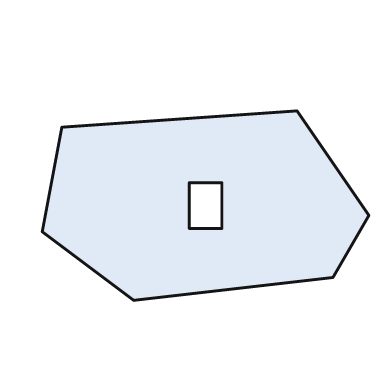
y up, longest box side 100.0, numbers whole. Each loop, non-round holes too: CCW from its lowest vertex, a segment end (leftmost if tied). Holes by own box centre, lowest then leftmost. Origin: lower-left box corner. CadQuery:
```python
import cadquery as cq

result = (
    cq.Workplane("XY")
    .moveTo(28.0, 0.0)
    .lineTo(89.0, 7.0)
    .lineTo(100.0, 26.0)
    .lineTo(78.0, 58.0)
    .lineTo(6.0, 53.0)
    .lineTo(0.0, 21.0)
    .close()
    .moveTo(45.0, 22.0)
    .lineTo(55.0, 22.0)
    .lineTo(55.0, 36.0)
    .lineTo(45.0, 36.0)
    .close()
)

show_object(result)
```